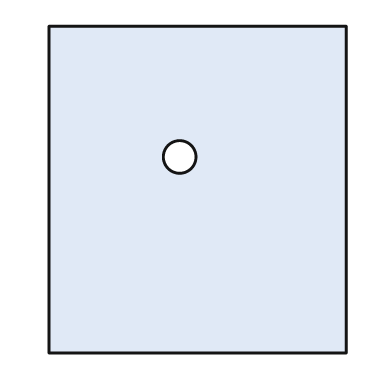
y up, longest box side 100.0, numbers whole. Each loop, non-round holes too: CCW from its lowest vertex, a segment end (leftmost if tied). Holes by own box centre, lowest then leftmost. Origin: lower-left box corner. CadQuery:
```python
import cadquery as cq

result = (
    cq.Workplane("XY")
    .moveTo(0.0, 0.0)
    .lineTo(91.0, 0.0)
    .lineTo(91.0, 100.0)
    .lineTo(0.0, 100.0)
    .close()
    .moveTo(40.0, 60.0)
    .circle(5.0)
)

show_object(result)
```